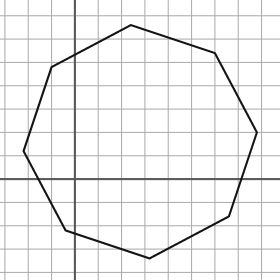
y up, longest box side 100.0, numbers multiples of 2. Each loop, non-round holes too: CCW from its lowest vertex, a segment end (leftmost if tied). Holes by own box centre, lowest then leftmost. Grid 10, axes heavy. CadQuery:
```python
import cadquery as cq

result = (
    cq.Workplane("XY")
    .moveTo(32.0, -34.0)
    .lineTo(66.0, -16.0)
    .lineTo(78.0, 20.0)
    .lineTo(60.0, 54.0)
    .lineTo(24.0, 66.0)
    .lineTo(-10.0, 48.0)
    .lineTo(-22.0, 12.0)
    .lineTo(-4.0, -22.0)
    .close()
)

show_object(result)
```